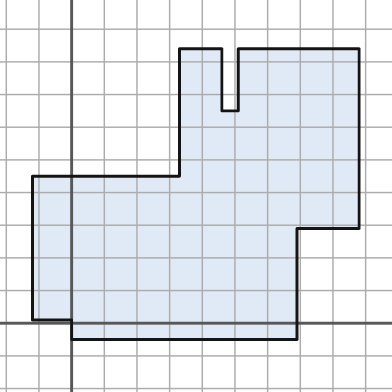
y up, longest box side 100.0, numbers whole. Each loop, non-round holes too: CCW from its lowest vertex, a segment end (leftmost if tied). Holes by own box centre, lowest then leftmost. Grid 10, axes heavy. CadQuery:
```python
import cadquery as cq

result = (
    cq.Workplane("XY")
    .moveTo(0.0, -5.0)
    .lineTo(69.0, -5.0)
    .lineTo(69.0, 29.0)
    .lineTo(88.0, 29.0)
    .lineTo(88.0, 84.0)
    .lineTo(51.0, 84.0)
    .lineTo(51.0, 65.0)
    .lineTo(46.0, 65.0)
    .lineTo(46.0, 84.0)
    .lineTo(33.0, 84.0)
    .lineTo(33.0, 45.0)
    .lineTo(-12.0, 45.0)
    .lineTo(-12.0, 1.0)
    .lineTo(0.0, 1.0)
    .close()
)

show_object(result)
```